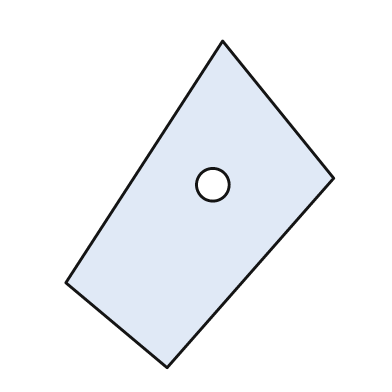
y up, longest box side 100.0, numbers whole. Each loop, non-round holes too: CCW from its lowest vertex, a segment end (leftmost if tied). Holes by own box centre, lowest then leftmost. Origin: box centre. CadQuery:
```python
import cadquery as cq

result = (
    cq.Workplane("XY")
    .moveTo(-10.0, -50.0)
    .lineTo(41.0, 8.0)
    .lineTo(7.0, 50.0)
    .lineTo(-41.0, -24.0)
    .close()
    .moveTo(4.0, 6.0)
    .circle(5.0)
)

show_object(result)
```